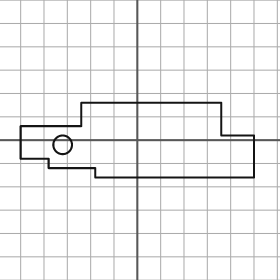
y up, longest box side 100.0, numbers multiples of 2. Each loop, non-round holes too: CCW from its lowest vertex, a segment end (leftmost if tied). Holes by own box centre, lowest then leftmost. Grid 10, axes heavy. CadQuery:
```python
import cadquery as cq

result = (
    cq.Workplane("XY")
    .moveTo(-18.0, -16.0)
    .lineTo(50.0, -16.0)
    .lineTo(50.0, 2.0)
    .lineTo(36.0, 2.0)
    .lineTo(36.0, 16.0)
    .lineTo(-24.0, 16.0)
    .lineTo(-24.0, 6.0)
    .lineTo(-50.0, 6.0)
    .lineTo(-50.0, -8.0)
    .lineTo(-38.0, -8.0)
    .lineTo(-38.0, -12.0)
    .lineTo(-18.0, -12.0)
    .close()
    .moveTo(-32.0, -2.0)
    .circle(4.0)
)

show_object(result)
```